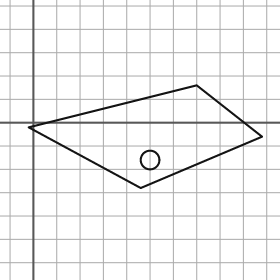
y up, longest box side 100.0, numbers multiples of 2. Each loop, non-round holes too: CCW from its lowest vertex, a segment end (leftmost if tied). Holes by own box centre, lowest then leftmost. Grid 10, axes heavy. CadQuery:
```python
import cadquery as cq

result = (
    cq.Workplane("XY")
    .moveTo(46.0, -28.0)
    .lineTo(98.0, -6.0)
    .lineTo(70.0, 16.0)
    .lineTo(-2.0, -2.0)
    .close()
    .moveTo(50.0, -16.0)
    .circle(4.0)
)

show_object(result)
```